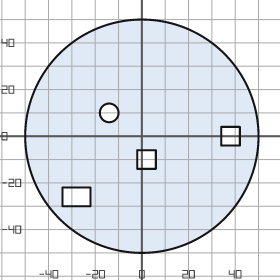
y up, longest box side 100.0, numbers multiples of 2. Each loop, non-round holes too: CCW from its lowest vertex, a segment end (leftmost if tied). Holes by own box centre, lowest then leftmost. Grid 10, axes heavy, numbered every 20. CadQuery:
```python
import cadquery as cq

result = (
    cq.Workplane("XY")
    .moveTo(0.0, 0.0)
    .circle(50.0)
    .moveTo(-34.0, -30.0)
    .lineTo(-22.0, -30.0)
    .lineTo(-22.0, -22.0)
    .lineTo(-34.0, -22.0)
    .close()
    .moveTo(-2.0, -14.0)
    .lineTo(6.0, -14.0)
    .lineTo(6.0, -6.0)
    .lineTo(-2.0, -6.0)
    .close()
    .moveTo(34.0, -4.0)
    .lineTo(42.0, -4.0)
    .lineTo(42.0, 4.0)
    .lineTo(34.0, 4.0)
    .close()
    .moveTo(-14.0, 10.0)
    .circle(4.0)
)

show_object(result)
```